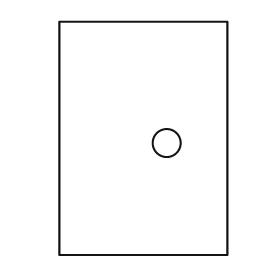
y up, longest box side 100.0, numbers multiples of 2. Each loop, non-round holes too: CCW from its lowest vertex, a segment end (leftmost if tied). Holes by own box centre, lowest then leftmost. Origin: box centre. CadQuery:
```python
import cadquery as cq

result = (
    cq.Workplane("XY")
    .moveTo(-36.0, -50.0)
    .lineTo(36.0, -50.0)
    .lineTo(36.0, 50.0)
    .lineTo(-36.0, 50.0)
    .close()
    .moveTo(10.0, -2.0)
    .circle(6.0)
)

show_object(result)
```